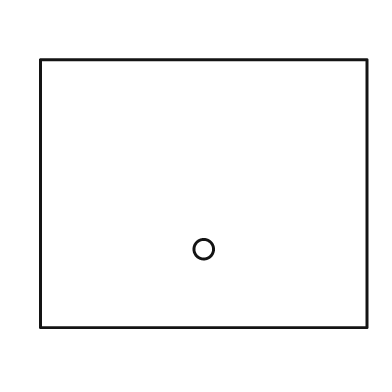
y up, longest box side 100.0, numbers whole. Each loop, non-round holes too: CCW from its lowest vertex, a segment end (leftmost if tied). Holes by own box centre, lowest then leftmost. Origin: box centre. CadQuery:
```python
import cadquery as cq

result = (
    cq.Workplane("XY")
    .moveTo(-50.0, -41.0)
    .lineTo(50.0, -41.0)
    .lineTo(50.0, 41.0)
    .lineTo(-50.0, 41.0)
    .close()
    .moveTo(0.0, -17.0)
    .circle(3.0)
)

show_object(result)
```